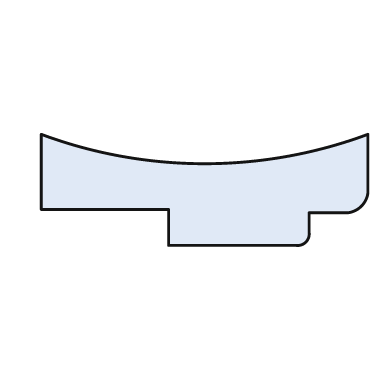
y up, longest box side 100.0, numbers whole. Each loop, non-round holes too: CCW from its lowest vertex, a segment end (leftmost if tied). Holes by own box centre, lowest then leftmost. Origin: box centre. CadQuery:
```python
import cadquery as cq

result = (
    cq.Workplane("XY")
    .moveTo(-11.0, -17.0)
    .lineTo(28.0, -17.0)
    .threePointArc((31.0, -16.0), (32.0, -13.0))
    .lineTo(32.0, -7.0)
    .lineTo(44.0, -7.0)
    .threePointArc((48.0, -5.0), (50.0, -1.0))
    .lineTo(50.0, 17.0)
    .threePointArc((0.0, 8.0), (-50.0, 17.0))
    .lineTo(-50.0, -6.0)
    .lineTo(-11.0, -6.0)
    .close()
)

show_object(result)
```